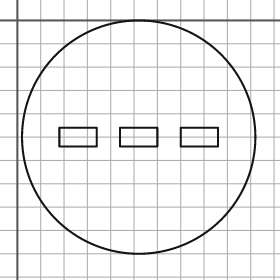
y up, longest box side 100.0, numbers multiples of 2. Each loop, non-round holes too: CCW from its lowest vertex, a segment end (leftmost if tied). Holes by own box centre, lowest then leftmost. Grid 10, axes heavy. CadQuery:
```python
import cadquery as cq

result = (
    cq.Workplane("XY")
    .moveTo(52.0, -50.0)
    .circle(50.0)
    .moveTo(18.0, -54.0)
    .lineTo(34.0, -54.0)
    .lineTo(34.0, -46.0)
    .lineTo(18.0, -46.0)
    .close()
    .moveTo(44.0, -54.0)
    .lineTo(60.0, -54.0)
    .lineTo(60.0, -46.0)
    .lineTo(44.0, -46.0)
    .close()
    .moveTo(70.0, -54.0)
    .lineTo(86.0, -54.0)
    .lineTo(86.0, -46.0)
    .lineTo(70.0, -46.0)
    .close()
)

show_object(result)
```